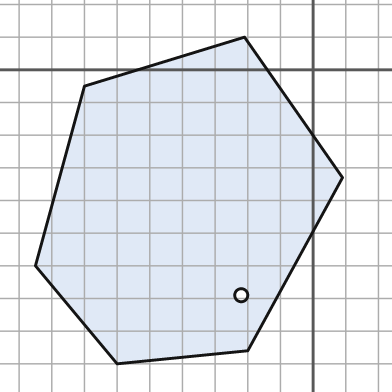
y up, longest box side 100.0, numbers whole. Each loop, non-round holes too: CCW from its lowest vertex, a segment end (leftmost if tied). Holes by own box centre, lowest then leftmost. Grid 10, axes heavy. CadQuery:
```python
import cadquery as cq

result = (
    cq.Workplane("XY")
    .moveTo(-60.0, -90.0)
    .lineTo(-20.0, -86.0)
    .lineTo(9.0, -33.0)
    .lineTo(-21.0, 10.0)
    .lineTo(-70.0, -5.0)
    .lineTo(-85.0, -60.0)
    .close()
    .moveTo(-22.0, -69.0)
    .circle(2.0)
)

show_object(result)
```